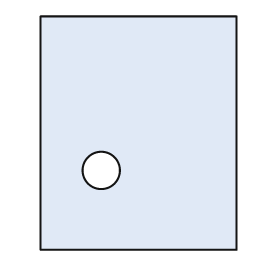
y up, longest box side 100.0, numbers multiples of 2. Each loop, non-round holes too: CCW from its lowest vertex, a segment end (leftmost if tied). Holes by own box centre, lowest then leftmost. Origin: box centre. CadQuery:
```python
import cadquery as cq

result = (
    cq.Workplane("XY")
    .moveTo(-42.0, -50.0)
    .lineTo(42.0, -50.0)
    .lineTo(42.0, 50.0)
    .lineTo(-42.0, 50.0)
    .close()
    .moveTo(-16.0, -16.0)
    .circle(8.0)
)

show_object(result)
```